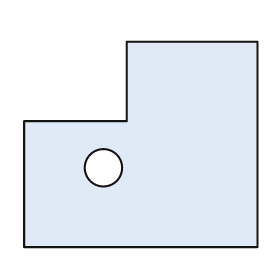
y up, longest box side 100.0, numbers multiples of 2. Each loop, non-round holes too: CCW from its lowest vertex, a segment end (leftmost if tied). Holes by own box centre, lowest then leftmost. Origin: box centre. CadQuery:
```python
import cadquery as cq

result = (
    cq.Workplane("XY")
    .moveTo(-50.0, -44.0)
    .lineTo(50.0, -44.0)
    .lineTo(50.0, 44.0)
    .lineTo(-6.0, 44.0)
    .lineTo(-6.0, 10.0)
    .lineTo(-50.0, 10.0)
    .close()
    .moveTo(-16.0, -10.0)
    .circle(8.0)
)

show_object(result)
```